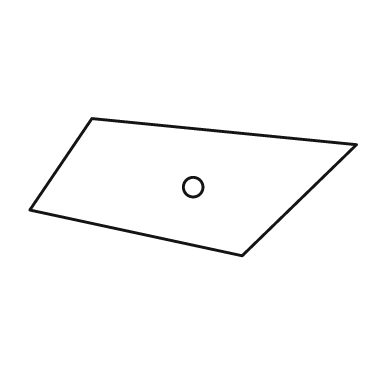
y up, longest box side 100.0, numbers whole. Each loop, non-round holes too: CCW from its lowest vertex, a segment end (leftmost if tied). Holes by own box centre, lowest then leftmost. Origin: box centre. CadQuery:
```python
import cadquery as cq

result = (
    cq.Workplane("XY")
    .moveTo(15.0, -21.0)
    .lineTo(50.0, 13.0)
    .lineTo(-31.0, 21.0)
    .lineTo(-50.0, -7.0)
    .close()
    .moveTo(0.0, 0.0)
    .circle(3.0)
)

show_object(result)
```